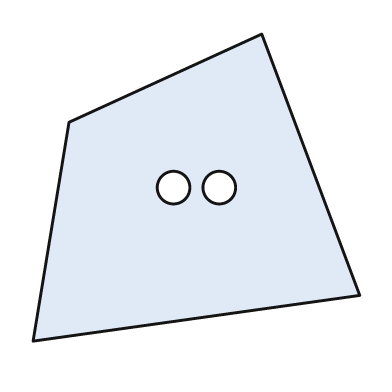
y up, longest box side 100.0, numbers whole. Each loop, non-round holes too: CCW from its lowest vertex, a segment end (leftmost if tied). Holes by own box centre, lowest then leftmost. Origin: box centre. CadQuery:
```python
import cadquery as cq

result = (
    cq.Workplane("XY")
    .moveTo(-50.0, -47.0)
    .lineTo(50.0, -33.0)
    .lineTo(20.0, 47.0)
    .lineTo(-39.0, 20.0)
    .close()
    .moveTo(-7.0, 0.0)
    .circle(5.0)
    .moveTo(7.0, 0.0)
    .circle(5.0)
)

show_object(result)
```